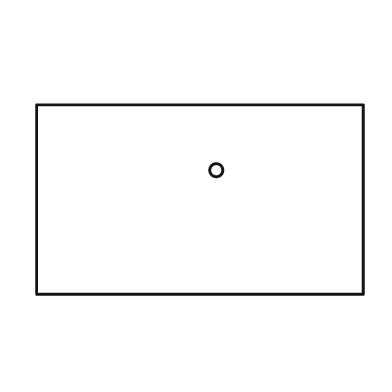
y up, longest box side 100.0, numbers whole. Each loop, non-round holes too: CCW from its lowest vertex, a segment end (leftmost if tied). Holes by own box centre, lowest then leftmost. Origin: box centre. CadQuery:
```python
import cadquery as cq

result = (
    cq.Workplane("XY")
    .moveTo(-50.0, -29.0)
    .lineTo(50.0, -29.0)
    .lineTo(50.0, 29.0)
    .lineTo(-50.0, 29.0)
    .close()
    .moveTo(5.0, 9.0)
    .circle(2.0)
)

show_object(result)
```